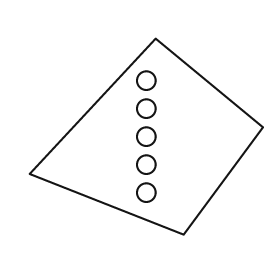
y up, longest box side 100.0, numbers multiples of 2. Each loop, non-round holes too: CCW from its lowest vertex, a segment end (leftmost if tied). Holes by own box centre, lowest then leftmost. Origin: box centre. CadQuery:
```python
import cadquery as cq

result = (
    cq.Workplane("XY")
    .moveTo(16.0, -42.0)
    .lineTo(50.0, 4.0)
    .lineTo(4.0, 42.0)
    .lineTo(-50.0, -16.0)
    .close()
    .moveTo(0.0, -24.0)
    .circle(4.0)
    .moveTo(0.0, -12.0)
    .circle(4.0)
    .moveTo(0.0, 0.0)
    .circle(4.0)
    .moveTo(0.0, 12.0)
    .circle(4.0)
    .moveTo(0.0, 24.0)
    .circle(4.0)
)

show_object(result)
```